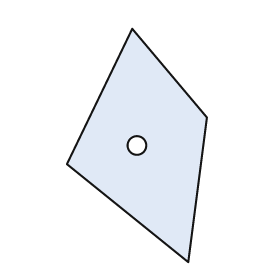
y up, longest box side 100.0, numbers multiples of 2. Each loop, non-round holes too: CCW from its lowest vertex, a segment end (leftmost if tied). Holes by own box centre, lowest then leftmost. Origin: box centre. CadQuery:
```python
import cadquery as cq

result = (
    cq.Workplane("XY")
    .moveTo(22.0, -50.0)
    .lineTo(30.0, 12.0)
    .lineTo(-2.0, 50.0)
    .lineTo(-30.0, -8.0)
    .close()
    .moveTo(0.0, 0.0)
    .circle(4.0)
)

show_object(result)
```